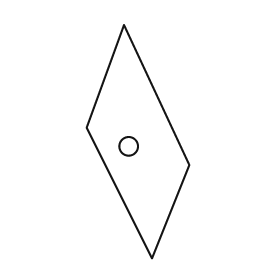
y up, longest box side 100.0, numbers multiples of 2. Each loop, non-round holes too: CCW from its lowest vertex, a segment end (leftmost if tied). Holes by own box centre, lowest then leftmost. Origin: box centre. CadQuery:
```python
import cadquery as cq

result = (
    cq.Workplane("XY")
    .moveTo(6.0, -50.0)
    .lineTo(22.0, -10.0)
    .lineTo(-6.0, 50.0)
    .lineTo(-22.0, 6.0)
    .close()
    .moveTo(-4.0, -2.0)
    .circle(4.0)
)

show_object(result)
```